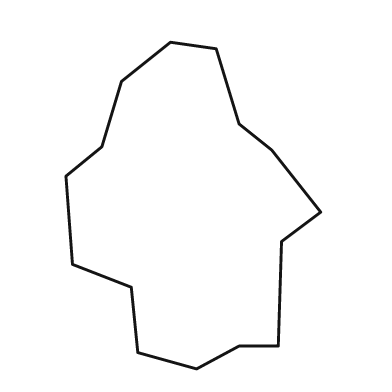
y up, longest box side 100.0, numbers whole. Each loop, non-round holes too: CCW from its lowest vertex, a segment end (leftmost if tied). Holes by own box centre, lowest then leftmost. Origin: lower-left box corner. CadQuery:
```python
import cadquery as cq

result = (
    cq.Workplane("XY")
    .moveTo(40.0, 0.0)
    .lineTo(53.0, 7.0)
    .lineTo(65.0, 7.0)
    .lineTo(66.0, 39.0)
    .lineTo(78.0, 48.0)
    .lineTo(63.0, 67.0)
    .lineTo(53.0, 75.0)
    .lineTo(46.0, 98.0)
    .lineTo(32.0, 100.0)
    .lineTo(17.0, 88.0)
    .lineTo(11.0, 68.0)
    .lineTo(0.0, 59.0)
    .lineTo(2.0, 32.0)
    .lineTo(20.0, 25.0)
    .lineTo(22.0, 5.0)
    .close()
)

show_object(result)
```